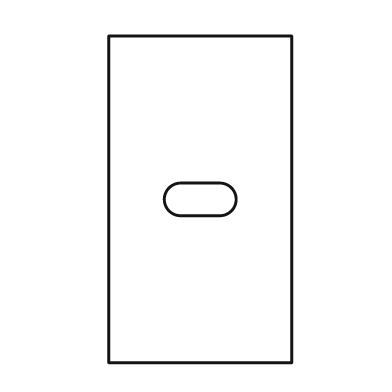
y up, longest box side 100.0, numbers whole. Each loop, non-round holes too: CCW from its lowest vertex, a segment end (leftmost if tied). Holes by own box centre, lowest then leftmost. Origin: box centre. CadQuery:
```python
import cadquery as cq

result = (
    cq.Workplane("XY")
    .moveTo(-28.0, -50.0)
    .lineTo(28.0, -50.0)
    .lineTo(28.0, 50.0)
    .lineTo(-28.0, 50.0)
    .close()
    .moveTo(-6.0, -5.0)
    .lineTo(6.0, -5.0)
    .threePointArc((11.0, 0.0), (6.0, 5.0))
    .lineTo(-6.0, 5.0)
    .threePointArc((-11.0, 0.0), (-6.0, -5.0))
    .close()
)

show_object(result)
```